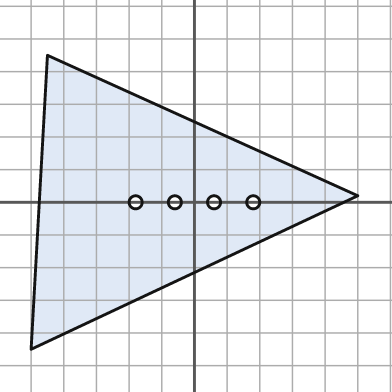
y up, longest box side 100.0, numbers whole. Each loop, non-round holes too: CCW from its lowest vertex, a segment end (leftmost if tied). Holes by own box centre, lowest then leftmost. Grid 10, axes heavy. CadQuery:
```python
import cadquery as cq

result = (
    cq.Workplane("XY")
    .moveTo(-50.0, -45.0)
    .lineTo(50.0, 2.0)
    .lineTo(-45.0, 45.0)
    .close()
    .moveTo(-18.0, 0.0)
    .circle(2.0)
    .moveTo(-6.0, 0.0)
    .circle(2.0)
    .moveTo(6.0, 0.0)
    .circle(2.0)
    .moveTo(18.0, 0.0)
    .circle(2.0)
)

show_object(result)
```